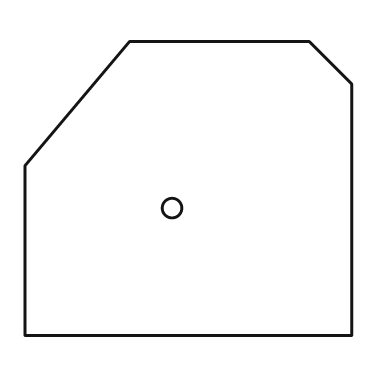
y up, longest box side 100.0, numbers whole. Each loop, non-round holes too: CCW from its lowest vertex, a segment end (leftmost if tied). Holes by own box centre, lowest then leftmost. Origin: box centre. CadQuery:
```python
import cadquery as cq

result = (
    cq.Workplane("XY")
    .moveTo(-50.0, -45.0)
    .lineTo(50.0, -45.0)
    .lineTo(50.0, 32.0)
    .lineTo(37.0, 45.0)
    .lineTo(-18.0, 45.0)
    .lineTo(-50.0, 7.0)
    .close()
    .moveTo(-5.0, -6.0)
    .circle(3.0)
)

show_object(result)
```